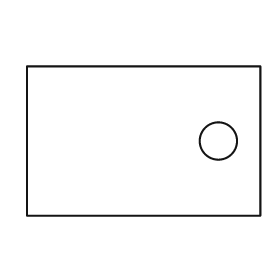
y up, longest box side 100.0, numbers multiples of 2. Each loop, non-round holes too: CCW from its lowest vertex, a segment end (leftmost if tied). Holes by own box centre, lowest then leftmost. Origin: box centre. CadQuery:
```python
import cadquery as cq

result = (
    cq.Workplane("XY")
    .moveTo(-50.0, -32.0)
    .lineTo(50.0, -32.0)
    .lineTo(50.0, 32.0)
    .lineTo(-50.0, 32.0)
    .close()
    .moveTo(32.0, 0.0)
    .circle(8.0)
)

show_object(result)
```